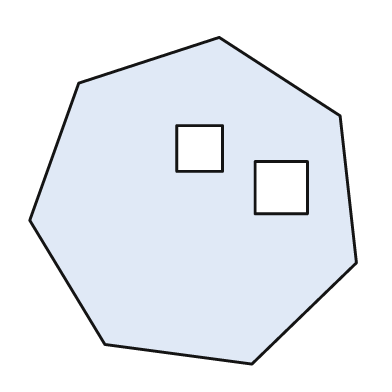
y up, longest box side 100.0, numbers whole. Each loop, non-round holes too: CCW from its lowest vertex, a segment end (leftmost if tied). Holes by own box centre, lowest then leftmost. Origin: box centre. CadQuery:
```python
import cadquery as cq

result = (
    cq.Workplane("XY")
    .moveTo(18.0, -50.0)
    .lineTo(50.0, -19.0)
    .lineTo(45.0, 26.0)
    .lineTo(8.0, 50.0)
    .lineTo(-35.0, 36.0)
    .lineTo(-50.0, -6.0)
    .lineTo(-27.0, -44.0)
    .close()
    .moveTo(19.0, -4.0)
    .lineTo(35.0, -4.0)
    .lineTo(35.0, 12.0)
    .lineTo(19.0, 12.0)
    .close()
    .moveTo(-5.0, 9.0)
    .lineTo(9.0, 9.0)
    .lineTo(9.0, 23.0)
    .lineTo(-5.0, 23.0)
    .close()
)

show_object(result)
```